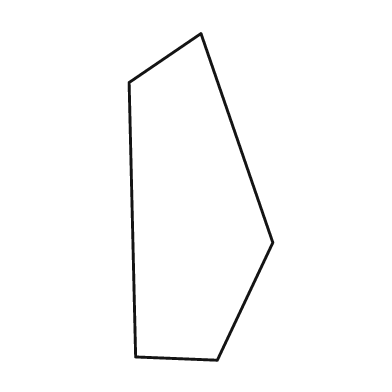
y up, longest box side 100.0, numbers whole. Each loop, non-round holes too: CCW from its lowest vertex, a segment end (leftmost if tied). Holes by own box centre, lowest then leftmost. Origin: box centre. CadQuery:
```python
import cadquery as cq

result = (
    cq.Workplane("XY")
    .moveTo(5.0, -50.0)
    .lineTo(22.0, -14.0)
    .lineTo(0.0, 50.0)
    .lineTo(-22.0, 35.0)
    .lineTo(-20.0, -49.0)
    .close()
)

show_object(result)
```